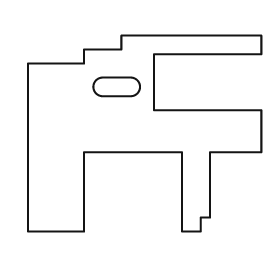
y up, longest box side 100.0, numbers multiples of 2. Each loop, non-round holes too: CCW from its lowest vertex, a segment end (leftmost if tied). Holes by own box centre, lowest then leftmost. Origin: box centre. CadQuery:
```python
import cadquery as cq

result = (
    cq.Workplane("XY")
    .moveTo(-50.0, -42.0)
    .lineTo(-26.0, -42.0)
    .lineTo(-26.0, -8.0)
    .lineTo(16.0, -8.0)
    .lineTo(16.0, -42.0)
    .lineTo(24.0, -42.0)
    .lineTo(24.0, -36.0)
    .lineTo(28.0, -36.0)
    .lineTo(28.0, -8.0)
    .lineTo(50.0, -8.0)
    .lineTo(50.0, 10.0)
    .lineTo(4.0, 10.0)
    .lineTo(4.0, 34.0)
    .lineTo(50.0, 34.0)
    .lineTo(50.0, 42.0)
    .lineTo(-10.0, 42.0)
    .lineTo(-10.0, 36.0)
    .lineTo(-26.0, 36.0)
    .lineTo(-26.0, 30.0)
    .lineTo(-50.0, 30.0)
    .close()
    .moveTo(-18.0, 16.0)
    .lineTo(-6.0, 16.0)
    .threePointArc((-2.0, 20.0), (-6.0, 24.0))
    .lineTo(-18.0, 24.0)
    .threePointArc((-22.0, 20.0), (-18.0, 16.0))
    .close()
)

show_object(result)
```